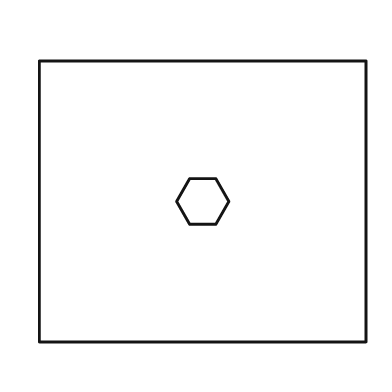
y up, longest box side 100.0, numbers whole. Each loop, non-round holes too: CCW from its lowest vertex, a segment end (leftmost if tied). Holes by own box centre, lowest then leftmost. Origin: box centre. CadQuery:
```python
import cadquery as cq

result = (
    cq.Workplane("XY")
    .moveTo(-50.0, -43.0)
    .lineTo(50.0, -43.0)
    .lineTo(50.0, 43.0)
    .lineTo(-50.0, 43.0)
    .close()
    .moveTo(-4.0, -7.0)
    .lineTo(4.0, -7.0)
    .lineTo(8.0, 0.0)
    .lineTo(4.0, 7.0)
    .lineTo(-4.0, 7.0)
    .lineTo(-8.0, 0.0)
    .close()
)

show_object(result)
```